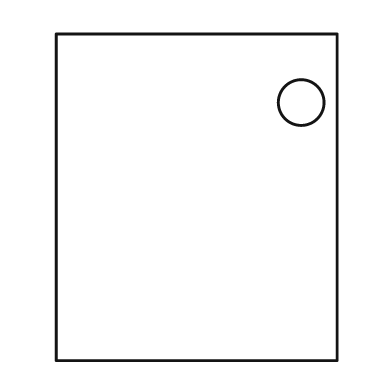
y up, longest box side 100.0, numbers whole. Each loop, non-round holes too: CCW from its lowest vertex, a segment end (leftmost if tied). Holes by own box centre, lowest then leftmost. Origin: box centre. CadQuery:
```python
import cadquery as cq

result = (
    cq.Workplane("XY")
    .moveTo(-43.0, -50.0)
    .lineTo(43.0, -50.0)
    .lineTo(43.0, 50.0)
    .lineTo(-43.0, 50.0)
    .close()
    .moveTo(32.0, 29.0)
    .circle(7.0)
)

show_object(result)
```